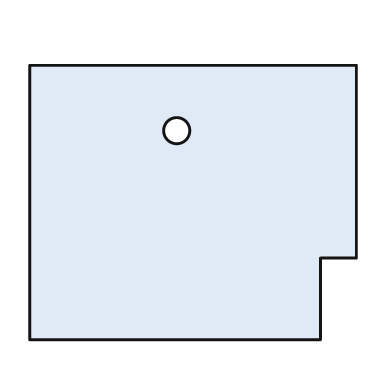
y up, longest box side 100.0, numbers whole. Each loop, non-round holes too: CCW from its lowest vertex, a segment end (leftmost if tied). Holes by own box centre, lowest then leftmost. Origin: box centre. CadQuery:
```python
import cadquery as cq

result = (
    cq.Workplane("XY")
    .moveTo(-50.0, -42.0)
    .lineTo(39.0, -42.0)
    .lineTo(39.0, -17.0)
    .lineTo(50.0, -17.0)
    .lineTo(50.0, 42.0)
    .lineTo(-50.0, 42.0)
    .close()
    .moveTo(-5.0, 22.0)
    .circle(4.0)
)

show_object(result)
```